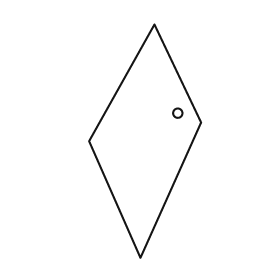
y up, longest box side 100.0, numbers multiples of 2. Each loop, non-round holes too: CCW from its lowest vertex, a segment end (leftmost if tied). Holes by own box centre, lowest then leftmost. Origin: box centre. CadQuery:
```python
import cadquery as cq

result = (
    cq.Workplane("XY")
    .moveTo(-2.0, -50.0)
    .lineTo(24.0, 8.0)
    .lineTo(4.0, 50.0)
    .lineTo(-24.0, 0.0)
    .close()
    .moveTo(14.0, 12.0)
    .circle(2.0)
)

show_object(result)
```